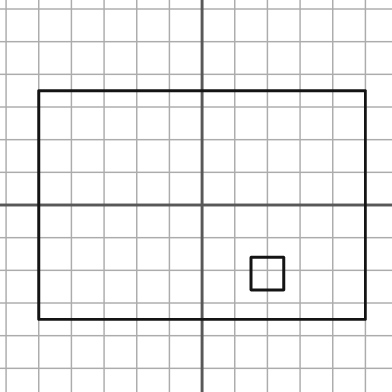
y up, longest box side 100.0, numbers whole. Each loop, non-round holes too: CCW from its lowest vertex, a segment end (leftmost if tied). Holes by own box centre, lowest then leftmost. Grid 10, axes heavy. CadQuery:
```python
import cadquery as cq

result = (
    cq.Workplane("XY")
    .moveTo(-50.0, -35.0)
    .lineTo(50.0, -35.0)
    .lineTo(50.0, 35.0)
    .lineTo(-50.0, 35.0)
    .close()
    .moveTo(15.0, -26.0)
    .lineTo(25.0, -26.0)
    .lineTo(25.0, -16.0)
    .lineTo(15.0, -16.0)
    .close()
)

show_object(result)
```